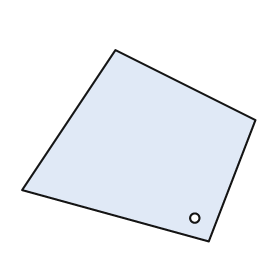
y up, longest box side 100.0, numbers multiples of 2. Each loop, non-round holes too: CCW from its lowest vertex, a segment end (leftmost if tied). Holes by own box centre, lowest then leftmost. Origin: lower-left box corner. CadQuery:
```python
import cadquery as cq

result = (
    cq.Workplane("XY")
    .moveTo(80.0, 0.0)
    .lineTo(100.0, 52.0)
    .lineTo(40.0, 82.0)
    .lineTo(0.0, 22.0)
    .close()
    .moveTo(74.0, 10.0)
    .circle(2.0)
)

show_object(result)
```